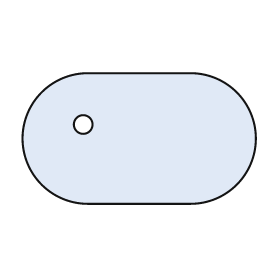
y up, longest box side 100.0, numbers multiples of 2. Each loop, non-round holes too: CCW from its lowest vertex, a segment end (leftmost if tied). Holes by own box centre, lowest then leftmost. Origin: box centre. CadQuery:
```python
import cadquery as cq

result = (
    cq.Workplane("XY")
    .moveTo(-22.0, -28.0)
    .lineTo(22.0, -28.0)
    .threePointArc((50.0, 0.0), (22.0, 28.0))
    .lineTo(-22.0, 28.0)
    .threePointArc((-50.0, 0.0), (-22.0, -28.0))
    .close()
    .moveTo(-24.0, 6.0)
    .circle(4.0)
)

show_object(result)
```